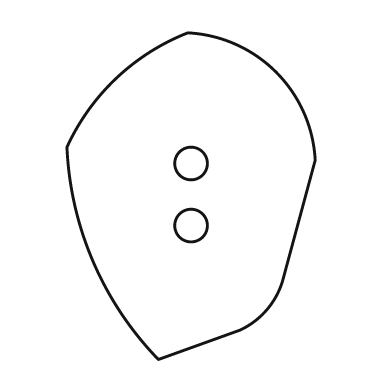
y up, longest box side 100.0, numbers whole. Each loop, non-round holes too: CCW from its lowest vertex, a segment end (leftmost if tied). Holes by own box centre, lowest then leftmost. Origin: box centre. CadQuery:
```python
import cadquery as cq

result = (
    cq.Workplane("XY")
    .moveTo(-10.0, -50.0)
    .lineTo(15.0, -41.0)
    .threePointArc((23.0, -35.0), (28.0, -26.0))
    .lineTo(38.0, 11.0)
    .threePointArc((26.0, 38.0), (-1.0, 50.0))
    .threePointArc((-23.0, 36.0), (-38.0, 15.0))
    .threePointArc((-30.0, -20.0), (-10.0, -50.0))
    .close()
    .moveTo(0.0, -9.0)
    .circle(5.0)
    .moveTo(0.0, 10.0)
    .circle(5.0)
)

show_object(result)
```